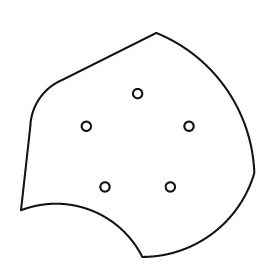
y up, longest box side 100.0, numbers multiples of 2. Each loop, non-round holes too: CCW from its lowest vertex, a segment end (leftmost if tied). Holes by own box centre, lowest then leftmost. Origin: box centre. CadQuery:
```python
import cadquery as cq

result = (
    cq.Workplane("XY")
    .moveTo(2.0, -48.0)
    .threePointArc((32.0, -38.0), (50.0, -12.0))
    .threePointArc((38.0, 24.0), (8.0, 48.0))
    .lineTo(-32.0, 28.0)
    .threePointArc((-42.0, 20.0), (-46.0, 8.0))
    .lineTo(-50.0, -28.0)
    .threePointArc((-20.0, -28.0), (2.0, -48.0))
    .close()
    .moveTo(-14.0, -18.0)
    .circle(2.0)
    .moveTo(14.0, -18.0)
    .circle(2.0)
    .moveTo(-22.0, 8.0)
    .circle(2.0)
    .moveTo(22.0, 8.0)
    .circle(2.0)
    .moveTo(0.0, 22.0)
    .circle(2.0)
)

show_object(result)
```